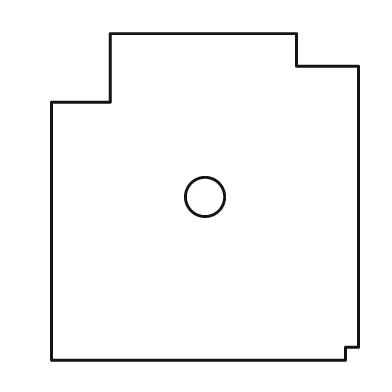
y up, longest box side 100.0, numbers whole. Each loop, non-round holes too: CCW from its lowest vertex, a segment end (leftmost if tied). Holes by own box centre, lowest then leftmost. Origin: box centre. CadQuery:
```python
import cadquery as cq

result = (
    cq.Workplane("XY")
    .moveTo(-47.0, -50.0)
    .lineTo(43.0, -50.0)
    .lineTo(43.0, -46.0)
    .lineTo(47.0, -46.0)
    .lineTo(47.0, 40.0)
    .lineTo(28.0, 40.0)
    .lineTo(28.0, 50.0)
    .lineTo(-29.0, 50.0)
    .lineTo(-29.0, 29.0)
    .lineTo(-47.0, 29.0)
    .close()
    .moveTo(0.0, 0.0)
    .circle(6.0)
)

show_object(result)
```